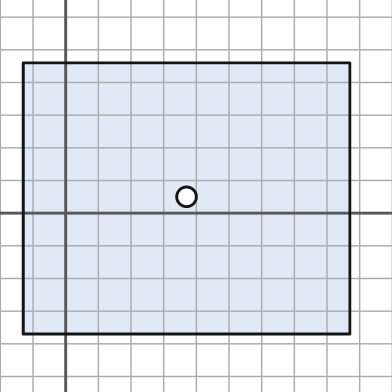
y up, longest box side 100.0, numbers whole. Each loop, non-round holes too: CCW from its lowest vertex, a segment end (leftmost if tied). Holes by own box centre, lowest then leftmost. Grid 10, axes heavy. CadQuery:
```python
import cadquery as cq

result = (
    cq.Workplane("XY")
    .moveTo(-13.0, -37.0)
    .lineTo(87.0, -37.0)
    .lineTo(87.0, 46.0)
    .lineTo(-13.0, 46.0)
    .close()
    .moveTo(37.0, 5.0)
    .circle(3.0)
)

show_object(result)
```